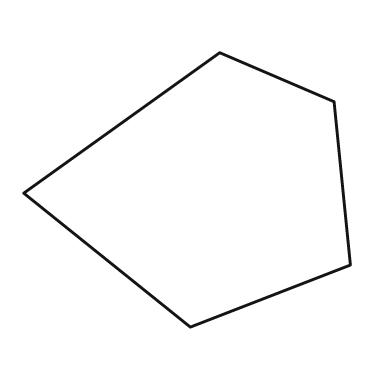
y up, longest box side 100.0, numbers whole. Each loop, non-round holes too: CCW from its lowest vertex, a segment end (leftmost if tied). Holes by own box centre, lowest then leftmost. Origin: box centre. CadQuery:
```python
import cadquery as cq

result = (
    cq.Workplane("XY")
    .moveTo(1.0, -42.0)
    .lineTo(50.0, -23.0)
    .lineTo(45.0, 27.0)
    .lineTo(10.0, 42.0)
    .lineTo(-50.0, -1.0)
    .close()
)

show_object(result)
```